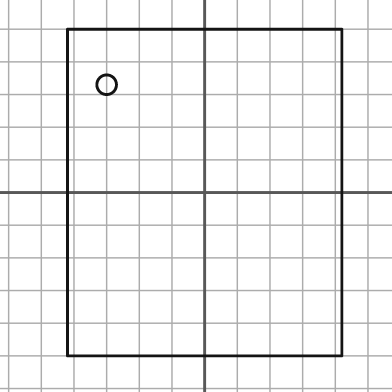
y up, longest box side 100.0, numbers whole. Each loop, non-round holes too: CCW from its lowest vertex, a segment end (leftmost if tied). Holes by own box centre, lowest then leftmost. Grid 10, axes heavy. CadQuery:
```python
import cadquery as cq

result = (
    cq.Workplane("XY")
    .moveTo(-42.0, -50.0)
    .lineTo(42.0, -50.0)
    .lineTo(42.0, 50.0)
    .lineTo(-42.0, 50.0)
    .close()
    .moveTo(-30.0, 33.0)
    .circle(3.0)
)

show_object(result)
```